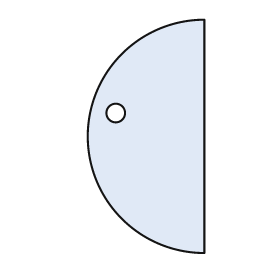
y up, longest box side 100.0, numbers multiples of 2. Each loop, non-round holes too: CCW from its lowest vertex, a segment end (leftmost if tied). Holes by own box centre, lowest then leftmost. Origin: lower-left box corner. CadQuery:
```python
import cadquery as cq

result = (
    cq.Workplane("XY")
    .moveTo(50.0, 0.0)
    .lineTo(50.0, 100.0)
    .threePointArc((0.0, 50.0), (50.0, 0.0))
    .close()
    .moveTo(12.0, 60.0)
    .circle(4.0)
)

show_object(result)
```